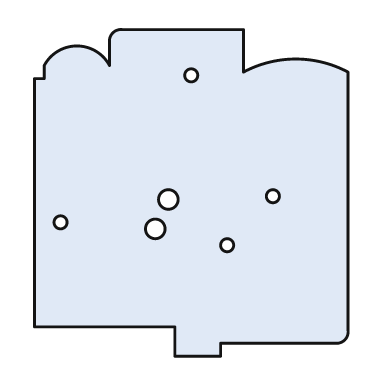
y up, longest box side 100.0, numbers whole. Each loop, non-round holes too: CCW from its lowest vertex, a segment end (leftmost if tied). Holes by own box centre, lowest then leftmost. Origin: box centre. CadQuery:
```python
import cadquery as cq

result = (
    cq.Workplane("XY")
    .moveTo(-5.0, -50.0)
    .lineTo(9.0, -50.0)
    .lineTo(9.0, -46.0)
    .lineTo(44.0, -46.0)
    .threePointArc((47.0, -45.0), (48.0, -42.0))
    .lineTo(48.0, 37.0)
    .threePointArc((32.0, 41.0), (16.0, 37.0))
    .lineTo(16.0, 50.0)
    .lineTo(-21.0, 50.0)
    .threePointArc((-24.0, 49.0), (-25.0, 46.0))
    .lineTo(-25.0, 39.0)
    .threePointArc((-35.0, 45.0), (-45.0, 39.0))
    .lineTo(-45.0, 35.0)
    .lineTo(-48.0, 35.0)
    .lineTo(-48.0, -41.0)
    .lineTo(-5.0, -41.0)
    .close()
    .moveTo(11.0, -16.0)
    .circle(2.0)
    .moveTo(-11.0, -11.0)
    .circle(3.0)
    .moveTo(-40.0, -9.0)
    .circle(2.0)
    .moveTo(-7.0, -2.0)
    .circle(3.0)
    .moveTo(25.0, -1.0)
    .circle(2.0)
    .moveTo(0.0, 36.0)
    .circle(2.0)
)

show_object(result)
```